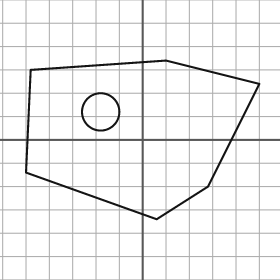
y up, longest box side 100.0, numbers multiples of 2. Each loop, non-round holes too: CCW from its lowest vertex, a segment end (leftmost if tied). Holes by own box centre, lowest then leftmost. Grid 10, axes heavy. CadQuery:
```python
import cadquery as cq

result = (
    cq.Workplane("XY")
    .moveTo(6.0, -34.0)
    .lineTo(28.0, -20.0)
    .lineTo(50.0, 24.0)
    .lineTo(10.0, 34.0)
    .lineTo(-48.0, 30.0)
    .lineTo(-50.0, -14.0)
    .close()
    .moveTo(-18.0, 12.0)
    .circle(8.0)
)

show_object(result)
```